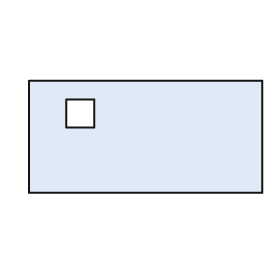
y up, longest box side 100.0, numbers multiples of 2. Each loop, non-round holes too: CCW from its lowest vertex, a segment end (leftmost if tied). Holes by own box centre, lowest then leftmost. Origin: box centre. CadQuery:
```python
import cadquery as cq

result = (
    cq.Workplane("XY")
    .moveTo(-50.0, -24.0)
    .lineTo(50.0, -24.0)
    .lineTo(50.0, 24.0)
    .lineTo(-50.0, 24.0)
    .close()
    .moveTo(-34.0, 4.0)
    .lineTo(-22.0, 4.0)
    .lineTo(-22.0, 16.0)
    .lineTo(-34.0, 16.0)
    .close()
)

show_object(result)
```